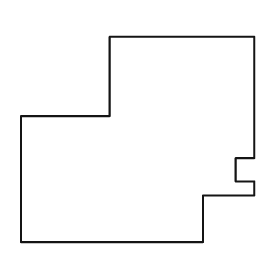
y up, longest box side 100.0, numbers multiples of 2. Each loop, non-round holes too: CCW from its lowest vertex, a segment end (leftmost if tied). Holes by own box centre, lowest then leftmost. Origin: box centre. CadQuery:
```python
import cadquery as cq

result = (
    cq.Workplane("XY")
    .moveTo(-50.0, -44.0)
    .lineTo(28.0, -44.0)
    .lineTo(28.0, -24.0)
    .lineTo(50.0, -24.0)
    .lineTo(50.0, -18.0)
    .lineTo(42.0, -18.0)
    .lineTo(42.0, -8.0)
    .lineTo(50.0, -8.0)
    .lineTo(50.0, 44.0)
    .lineTo(-12.0, 44.0)
    .lineTo(-12.0, 10.0)
    .lineTo(-50.0, 10.0)
    .close()
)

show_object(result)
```